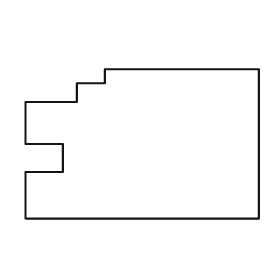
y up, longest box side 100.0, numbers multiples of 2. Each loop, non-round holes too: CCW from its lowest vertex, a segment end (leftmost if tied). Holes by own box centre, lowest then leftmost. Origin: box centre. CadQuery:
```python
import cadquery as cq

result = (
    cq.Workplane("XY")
    .moveTo(-50.0, -32.0)
    .lineTo(50.0, -32.0)
    .lineTo(50.0, 32.0)
    .lineTo(-16.0, 32.0)
    .lineTo(-16.0, 26.0)
    .lineTo(-28.0, 26.0)
    .lineTo(-28.0, 18.0)
    .lineTo(-50.0, 18.0)
    .lineTo(-50.0, 0.0)
    .lineTo(-34.0, 0.0)
    .lineTo(-34.0, -12.0)
    .lineTo(-50.0, -12.0)
    .close()
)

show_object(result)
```